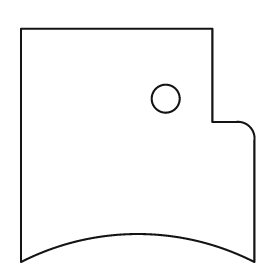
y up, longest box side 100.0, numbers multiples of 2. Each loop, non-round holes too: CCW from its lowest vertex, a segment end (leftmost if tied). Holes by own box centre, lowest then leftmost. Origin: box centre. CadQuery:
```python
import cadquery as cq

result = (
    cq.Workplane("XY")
    .moveTo(-50.0, -50.0)
    .threePointArc((0.0, -38.0), (50.0, -50.0))
    .lineTo(50.0, 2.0)
    .threePointArc((48.0, 8.0), (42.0, 10.0))
    .lineTo(32.0, 10.0)
    .lineTo(32.0, 50.0)
    .lineTo(-50.0, 50.0)
    .close()
    .moveTo(12.0, 20.0)
    .circle(6.0)
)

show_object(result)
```